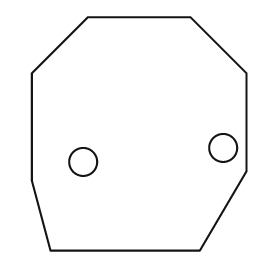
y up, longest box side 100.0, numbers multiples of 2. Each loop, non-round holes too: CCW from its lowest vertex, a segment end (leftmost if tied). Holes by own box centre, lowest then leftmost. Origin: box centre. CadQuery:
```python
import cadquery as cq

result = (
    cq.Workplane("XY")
    .moveTo(-38.0, -50.0)
    .lineTo(26.0, -50.0)
    .lineTo(46.0, -16.0)
    .lineTo(46.0, 26.0)
    .lineTo(22.0, 50.0)
    .lineTo(-22.0, 50.0)
    .lineTo(-46.0, 26.0)
    .lineTo(-46.0, -20.0)
    .close()
    .moveTo(-24.0, -12.0)
    .circle(6.0)
    .moveTo(36.0, -6.0)
    .circle(6.0)
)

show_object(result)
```